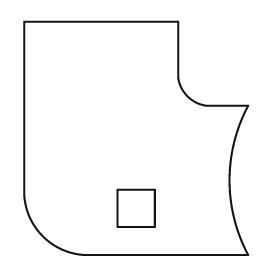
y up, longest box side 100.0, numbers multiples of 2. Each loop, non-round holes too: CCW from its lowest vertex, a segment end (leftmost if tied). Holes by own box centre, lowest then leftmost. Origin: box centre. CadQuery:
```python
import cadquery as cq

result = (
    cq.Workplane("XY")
    .moveTo(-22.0, -50.0)
    .lineTo(48.0, -50.0)
    .threePointArc((40.0, -18.0), (48.0, 14.0))
    .lineTo(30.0, 14.0)
    .threePointArc((22.0, 18.0), (18.0, 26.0))
    .lineTo(18.0, 50.0)
    .lineTo(-48.0, 50.0)
    .lineTo(-48.0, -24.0)
    .threePointArc((-40.0, -42.0), (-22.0, -50.0))
    .close()
    .moveTo(-8.0, -38.0)
    .lineTo(8.0, -38.0)
    .lineTo(8.0, -22.0)
    .lineTo(-8.0, -22.0)
    .close()
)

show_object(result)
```